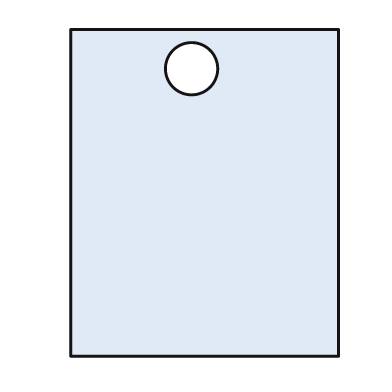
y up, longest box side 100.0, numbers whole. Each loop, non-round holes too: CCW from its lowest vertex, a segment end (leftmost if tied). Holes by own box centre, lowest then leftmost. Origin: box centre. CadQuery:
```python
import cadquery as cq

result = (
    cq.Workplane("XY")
    .moveTo(-41.0, -50.0)
    .lineTo(41.0, -50.0)
    .lineTo(41.0, 50.0)
    .lineTo(-41.0, 50.0)
    .close()
    .moveTo(-4.0, 38.0)
    .circle(8.0)
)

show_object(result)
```